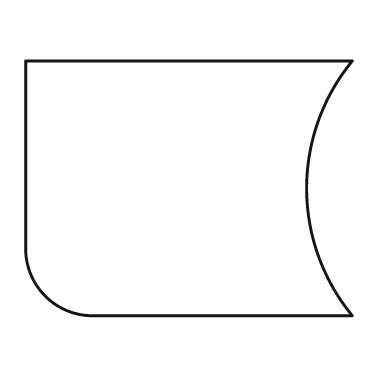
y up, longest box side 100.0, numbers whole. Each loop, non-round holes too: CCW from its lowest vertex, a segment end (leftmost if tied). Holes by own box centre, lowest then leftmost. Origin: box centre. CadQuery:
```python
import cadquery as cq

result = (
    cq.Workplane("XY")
    .moveTo(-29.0, -39.0)
    .lineTo(50.0, -39.0)
    .threePointArc((36.0, 0.0), (50.0, 39.0))
    .lineTo(-50.0, 39.0)
    .lineTo(-50.0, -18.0)
    .threePointArc((-44.0, -33.0), (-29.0, -39.0))
    .close()
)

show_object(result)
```